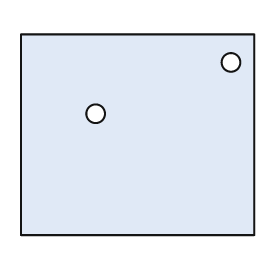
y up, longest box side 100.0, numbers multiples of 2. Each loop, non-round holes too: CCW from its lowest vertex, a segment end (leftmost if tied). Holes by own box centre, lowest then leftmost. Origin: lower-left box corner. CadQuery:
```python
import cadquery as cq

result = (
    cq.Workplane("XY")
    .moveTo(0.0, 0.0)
    .lineTo(100.0, 0.0)
    .lineTo(100.0, 86.0)
    .lineTo(0.0, 86.0)
    .close()
    .moveTo(32.0, 52.0)
    .circle(4.0)
    .moveTo(90.0, 74.0)
    .circle(4.0)
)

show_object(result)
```